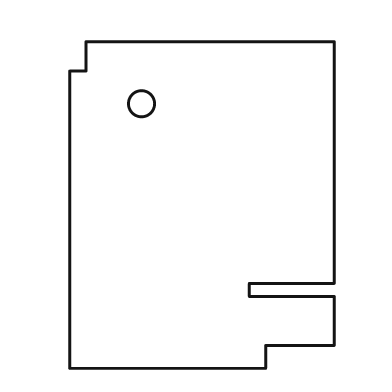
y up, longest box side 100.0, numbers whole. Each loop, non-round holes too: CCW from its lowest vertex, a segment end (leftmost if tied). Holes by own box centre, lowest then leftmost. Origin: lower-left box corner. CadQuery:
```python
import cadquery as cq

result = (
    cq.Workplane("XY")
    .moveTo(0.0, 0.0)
    .lineTo(60.0, 0.0)
    .lineTo(60.0, 7.0)
    .lineTo(81.0, 7.0)
    .lineTo(81.0, 22.0)
    .lineTo(55.0, 22.0)
    .lineTo(55.0, 26.0)
    .lineTo(81.0, 26.0)
    .lineTo(81.0, 100.0)
    .lineTo(5.0, 100.0)
    .lineTo(5.0, 91.0)
    .lineTo(0.0, 91.0)
    .close()
    .moveTo(22.0, 81.0)
    .circle(4.0)
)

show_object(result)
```